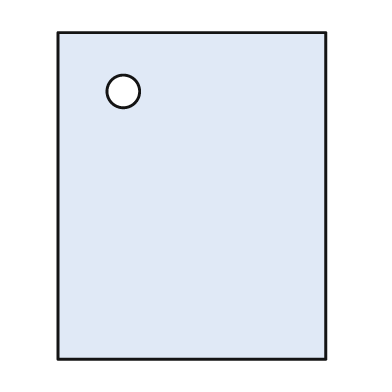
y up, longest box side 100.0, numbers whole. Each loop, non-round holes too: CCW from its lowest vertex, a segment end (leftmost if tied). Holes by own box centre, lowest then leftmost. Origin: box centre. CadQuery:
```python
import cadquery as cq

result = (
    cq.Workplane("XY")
    .moveTo(-41.0, -50.0)
    .lineTo(41.0, -50.0)
    .lineTo(41.0, 50.0)
    .lineTo(-41.0, 50.0)
    .close()
    .moveTo(-21.0, 32.0)
    .circle(5.0)
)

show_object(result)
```